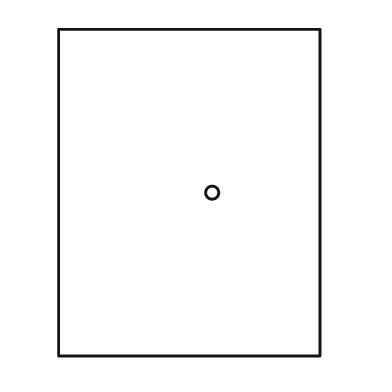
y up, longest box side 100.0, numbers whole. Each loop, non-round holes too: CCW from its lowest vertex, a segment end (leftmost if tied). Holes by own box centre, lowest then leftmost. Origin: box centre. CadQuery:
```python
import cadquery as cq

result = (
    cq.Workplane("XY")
    .moveTo(-40.0, -50.0)
    .lineTo(40.0, -50.0)
    .lineTo(40.0, 50.0)
    .lineTo(-40.0, 50.0)
    .close()
    .moveTo(7.0, 0.0)
    .circle(2.0)
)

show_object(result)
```